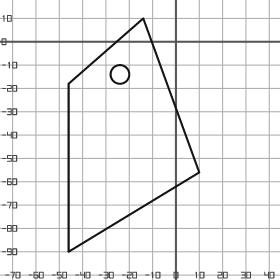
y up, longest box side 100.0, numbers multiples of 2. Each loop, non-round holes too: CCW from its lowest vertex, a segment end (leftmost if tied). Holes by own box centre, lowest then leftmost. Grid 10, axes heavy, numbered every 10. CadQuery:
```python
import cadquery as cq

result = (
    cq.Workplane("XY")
    .moveTo(-46.0, -90.0)
    .lineTo(10.0, -56.0)
    .lineTo(-14.0, 10.0)
    .lineTo(-46.0, -18.0)
    .close()
    .moveTo(-24.0, -14.0)
    .circle(4.0)
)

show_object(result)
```